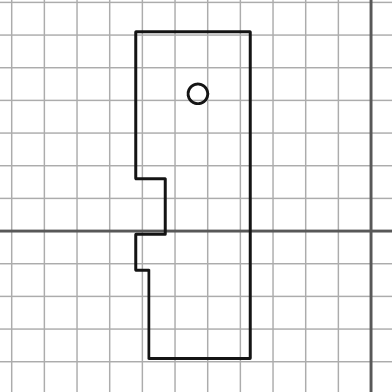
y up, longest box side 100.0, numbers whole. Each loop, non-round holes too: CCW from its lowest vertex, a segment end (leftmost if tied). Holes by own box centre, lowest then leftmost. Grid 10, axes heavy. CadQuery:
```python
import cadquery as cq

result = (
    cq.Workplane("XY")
    .moveTo(-68.0, -39.0)
    .lineTo(-37.0, -39.0)
    .lineTo(-37.0, 61.0)
    .lineTo(-72.0, 61.0)
    .lineTo(-72.0, 16.0)
    .lineTo(-63.0, 16.0)
    .lineTo(-63.0, -1.0)
    .lineTo(-72.0, -1.0)
    .lineTo(-72.0, -12.0)
    .lineTo(-68.0, -12.0)
    .close()
    .moveTo(-53.0, 42.0)
    .circle(3.0)
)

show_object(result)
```